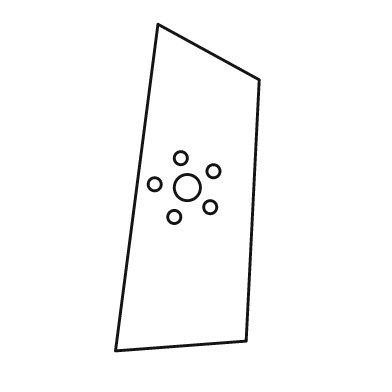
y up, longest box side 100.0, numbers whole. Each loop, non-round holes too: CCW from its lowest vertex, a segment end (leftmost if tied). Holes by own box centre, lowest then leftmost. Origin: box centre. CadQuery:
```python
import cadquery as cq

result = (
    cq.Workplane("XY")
    .moveTo(-22.0, -50.0)
    .lineTo(18.0, -47.0)
    .lineTo(22.0, 33.0)
    .lineTo(-9.0, 50.0)
    .close()
    .moveTo(-4.0, -9.0)
    .circle(2.0)
    .moveTo(7.0, -6.0)
    .circle(2.0)
    .moveTo(0.0, 0.0)
    .circle(4.0)
    .moveTo(-10.0, 1.0)
    .circle(2.0)
    .moveTo(8.0, 5.0)
    .circle(2.0)
    .moveTo(-2.0, 9.0)
    .circle(2.0)
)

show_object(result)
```